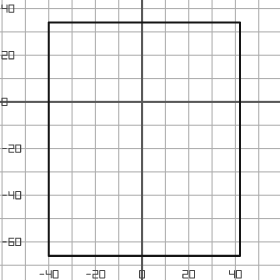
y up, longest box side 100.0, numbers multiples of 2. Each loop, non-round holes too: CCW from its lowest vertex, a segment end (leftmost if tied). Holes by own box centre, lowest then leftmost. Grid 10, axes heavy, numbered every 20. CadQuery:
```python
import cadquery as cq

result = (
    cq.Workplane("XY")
    .moveTo(-40.0, -66.0)
    .lineTo(42.0, -66.0)
    .lineTo(42.0, 34.0)
    .lineTo(-40.0, 34.0)
    .close()
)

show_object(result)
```